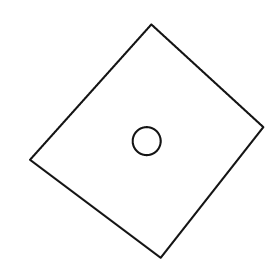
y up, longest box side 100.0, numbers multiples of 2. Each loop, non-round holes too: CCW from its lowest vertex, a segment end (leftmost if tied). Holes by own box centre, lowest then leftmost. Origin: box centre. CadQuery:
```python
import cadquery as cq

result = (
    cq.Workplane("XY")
    .moveTo(6.0, -50.0)
    .lineTo(50.0, 6.0)
    .lineTo(2.0, 50.0)
    .lineTo(-50.0, -8.0)
    .close()
    .moveTo(0.0, 0.0)
    .circle(6.0)
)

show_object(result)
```